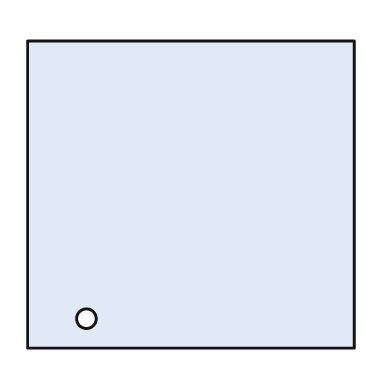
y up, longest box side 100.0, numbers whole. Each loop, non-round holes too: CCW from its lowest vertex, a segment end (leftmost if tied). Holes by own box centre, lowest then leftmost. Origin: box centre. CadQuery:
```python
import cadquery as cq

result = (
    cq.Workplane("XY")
    .moveTo(-50.0, -47.0)
    .lineTo(50.0, -47.0)
    .lineTo(50.0, 47.0)
    .lineTo(-50.0, 47.0)
    .close()
    .moveTo(-32.0, -38.0)
    .circle(3.0)
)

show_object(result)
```